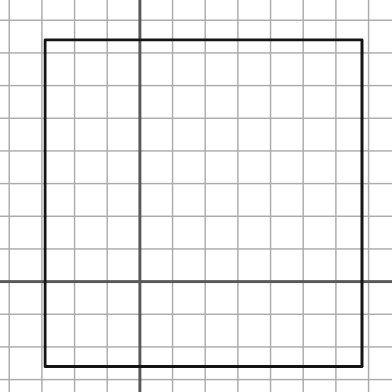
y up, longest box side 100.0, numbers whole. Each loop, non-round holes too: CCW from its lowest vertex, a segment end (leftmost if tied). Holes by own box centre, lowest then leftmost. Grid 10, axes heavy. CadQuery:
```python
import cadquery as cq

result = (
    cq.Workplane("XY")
    .moveTo(-29.0, -26.0)
    .lineTo(68.0, -26.0)
    .lineTo(68.0, 74.0)
    .lineTo(-29.0, 74.0)
    .close()
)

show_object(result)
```